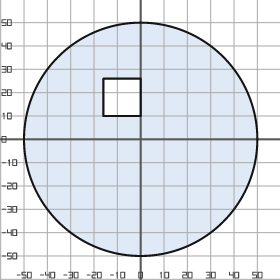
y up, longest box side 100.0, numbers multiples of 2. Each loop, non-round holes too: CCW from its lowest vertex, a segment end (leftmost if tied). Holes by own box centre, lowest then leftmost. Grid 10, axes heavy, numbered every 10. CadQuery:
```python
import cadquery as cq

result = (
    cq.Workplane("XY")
    .moveTo(0.0, 0.0)
    .circle(50.0)
    .moveTo(-16.0, 10.0)
    .lineTo(0.0, 10.0)
    .lineTo(0.0, 26.0)
    .lineTo(-16.0, 26.0)
    .close()
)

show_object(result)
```